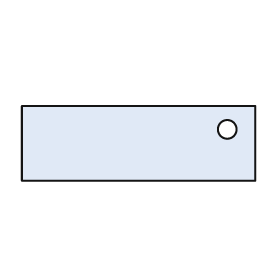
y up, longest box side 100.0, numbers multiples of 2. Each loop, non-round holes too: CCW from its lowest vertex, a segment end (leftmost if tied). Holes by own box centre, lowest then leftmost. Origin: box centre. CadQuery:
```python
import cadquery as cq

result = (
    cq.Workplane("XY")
    .moveTo(-50.0, -16.0)
    .lineTo(50.0, -16.0)
    .lineTo(50.0, 16.0)
    .lineTo(-50.0, 16.0)
    .close()
    .moveTo(38.0, 6.0)
    .circle(4.0)
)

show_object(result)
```